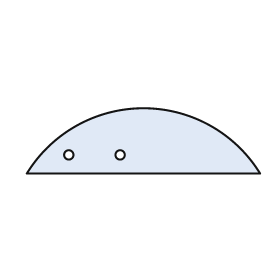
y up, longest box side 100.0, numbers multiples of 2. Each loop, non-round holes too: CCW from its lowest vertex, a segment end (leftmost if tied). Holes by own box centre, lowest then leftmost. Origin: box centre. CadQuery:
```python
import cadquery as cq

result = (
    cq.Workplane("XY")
    .moveTo(-50.0, -14.0)
    .lineTo(50.0, -14.0)
    .threePointArc((0.0, 14.0), (-50.0, -14.0))
    .close()
    .moveTo(-32.0, -6.0)
    .circle(2.0)
    .moveTo(-10.0, -6.0)
    .circle(2.0)
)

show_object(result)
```